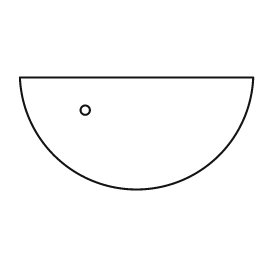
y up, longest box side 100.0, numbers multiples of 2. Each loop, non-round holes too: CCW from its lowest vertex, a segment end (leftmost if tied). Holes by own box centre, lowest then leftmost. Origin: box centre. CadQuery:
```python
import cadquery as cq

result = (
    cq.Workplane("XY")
    .moveTo(-50.0, 24.0)
    .threePointArc((0.0, -24.0), (50.0, 24.0))
    .close()
    .moveTo(-22.0, 10.0)
    .circle(2.0)
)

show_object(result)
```